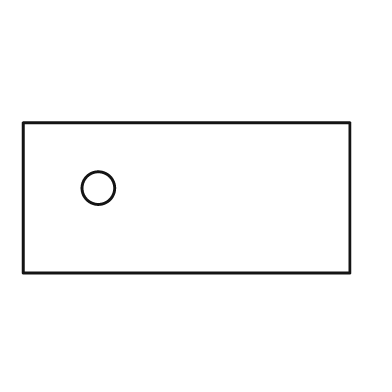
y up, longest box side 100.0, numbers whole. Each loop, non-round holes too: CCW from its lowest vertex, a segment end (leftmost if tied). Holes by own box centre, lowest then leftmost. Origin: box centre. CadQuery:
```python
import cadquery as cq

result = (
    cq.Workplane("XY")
    .moveTo(-50.0, -23.0)
    .lineTo(50.0, -23.0)
    .lineTo(50.0, 23.0)
    .lineTo(-50.0, 23.0)
    .close()
    .moveTo(-27.0, 3.0)
    .circle(5.0)
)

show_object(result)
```